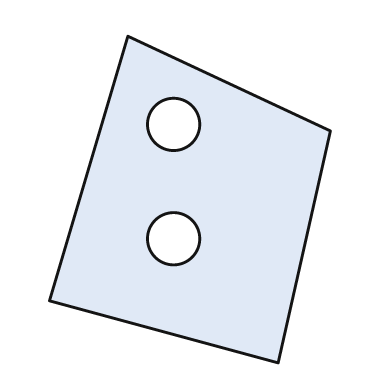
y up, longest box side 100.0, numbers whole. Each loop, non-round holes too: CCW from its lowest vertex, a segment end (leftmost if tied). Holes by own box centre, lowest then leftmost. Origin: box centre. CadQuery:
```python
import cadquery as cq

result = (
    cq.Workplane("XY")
    .moveTo(27.0, -50.0)
    .lineTo(43.0, 21.0)
    .lineTo(-19.0, 50.0)
    .lineTo(-43.0, -31.0)
    .close()
    .moveTo(-5.0, -12.0)
    .circle(8.0)
    .moveTo(-5.0, 23.0)
    .circle(8.0)
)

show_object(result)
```